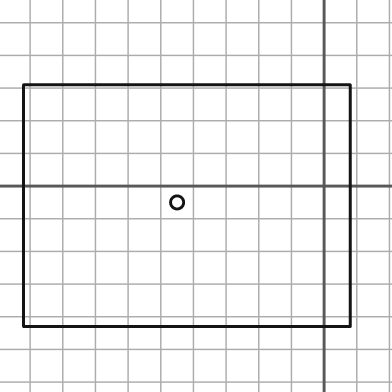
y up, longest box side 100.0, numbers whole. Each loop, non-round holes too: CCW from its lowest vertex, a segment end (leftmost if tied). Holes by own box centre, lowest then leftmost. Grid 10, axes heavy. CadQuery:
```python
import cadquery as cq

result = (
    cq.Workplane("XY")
    .moveTo(-92.0, -43.0)
    .lineTo(8.0, -43.0)
    .lineTo(8.0, 31.0)
    .lineTo(-92.0, 31.0)
    .close()
    .moveTo(-45.0, -5.0)
    .circle(2.0)
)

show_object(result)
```